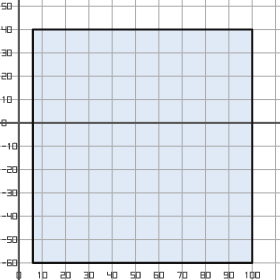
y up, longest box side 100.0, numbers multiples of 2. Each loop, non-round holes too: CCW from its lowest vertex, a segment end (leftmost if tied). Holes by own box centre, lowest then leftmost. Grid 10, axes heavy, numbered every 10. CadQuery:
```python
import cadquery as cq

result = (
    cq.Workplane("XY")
    .moveTo(6.0, -60.0)
    .lineTo(100.0, -60.0)
    .lineTo(100.0, 40.0)
    .lineTo(6.0, 40.0)
    .close()
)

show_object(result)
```